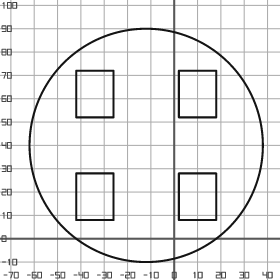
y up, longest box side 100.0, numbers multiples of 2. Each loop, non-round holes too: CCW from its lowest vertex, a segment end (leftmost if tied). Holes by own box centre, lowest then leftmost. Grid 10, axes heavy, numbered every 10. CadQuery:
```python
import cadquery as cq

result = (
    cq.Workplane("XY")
    .moveTo(-12.0, 40.0)
    .circle(50.0)
    .moveTo(-42.0, 8.0)
    .lineTo(-26.0, 8.0)
    .lineTo(-26.0, 28.0)
    .lineTo(-42.0, 28.0)
    .close()
    .moveTo(2.0, 8.0)
    .lineTo(18.0, 8.0)
    .lineTo(18.0, 28.0)
    .lineTo(2.0, 28.0)
    .close()
    .moveTo(-42.0, 52.0)
    .lineTo(-26.0, 52.0)
    .lineTo(-26.0, 72.0)
    .lineTo(-42.0, 72.0)
    .close()
    .moveTo(2.0, 52.0)
    .lineTo(18.0, 52.0)
    .lineTo(18.0, 72.0)
    .lineTo(2.0, 72.0)
    .close()
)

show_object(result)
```